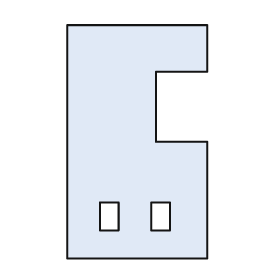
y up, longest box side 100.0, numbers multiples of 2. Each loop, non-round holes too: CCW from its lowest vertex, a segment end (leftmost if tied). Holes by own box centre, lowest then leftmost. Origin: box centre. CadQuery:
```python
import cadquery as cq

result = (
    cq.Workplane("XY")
    .moveTo(-30.0, -50.0)
    .lineTo(30.0, -50.0)
    .lineTo(30.0, 0.0)
    .lineTo(8.0, 0.0)
    .lineTo(8.0, 30.0)
    .lineTo(30.0, 30.0)
    .lineTo(30.0, 50.0)
    .lineTo(-30.0, 50.0)
    .close()
    .moveTo(-16.0, -38.0)
    .lineTo(-8.0, -38.0)
    .lineTo(-8.0, -26.0)
    .lineTo(-16.0, -26.0)
    .close()
    .moveTo(6.0, -38.0)
    .lineTo(14.0, -38.0)
    .lineTo(14.0, -26.0)
    .lineTo(6.0, -26.0)
    .close()
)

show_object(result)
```